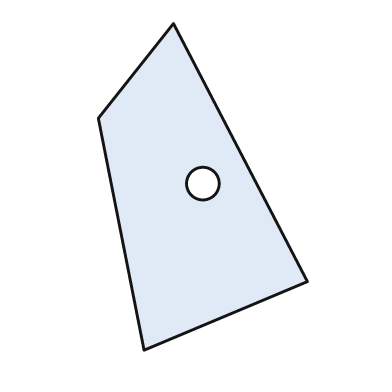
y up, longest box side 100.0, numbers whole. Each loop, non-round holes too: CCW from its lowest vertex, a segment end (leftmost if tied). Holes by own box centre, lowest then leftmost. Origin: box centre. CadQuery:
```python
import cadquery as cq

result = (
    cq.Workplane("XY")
    .moveTo(-18.0, -50.0)
    .lineTo(32.0, -29.0)
    .lineTo(-9.0, 50.0)
    .lineTo(-32.0, 21.0)
    .close()
    .moveTo(0.0, 1.0)
    .circle(5.0)
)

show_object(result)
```